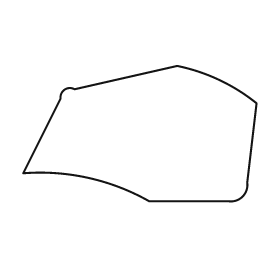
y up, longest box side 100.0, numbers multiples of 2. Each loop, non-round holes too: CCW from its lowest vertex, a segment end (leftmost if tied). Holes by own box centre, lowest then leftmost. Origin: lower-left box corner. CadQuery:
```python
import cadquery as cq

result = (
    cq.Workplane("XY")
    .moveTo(54.0, 0.0)
    .lineTo(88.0, 0.0)
    .threePointArc((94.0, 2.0), (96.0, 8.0))
    .lineTo(100.0, 42.0)
    .threePointArc((84.0, 52.0), (66.0, 58.0))
    .lineTo(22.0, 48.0)
    .threePointArc((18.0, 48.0), (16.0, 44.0))
    .lineTo(0.0, 12.0)
    .threePointArc((28.0, 10.0), (54.0, 0.0))
    .close()
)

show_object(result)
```